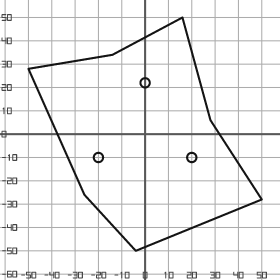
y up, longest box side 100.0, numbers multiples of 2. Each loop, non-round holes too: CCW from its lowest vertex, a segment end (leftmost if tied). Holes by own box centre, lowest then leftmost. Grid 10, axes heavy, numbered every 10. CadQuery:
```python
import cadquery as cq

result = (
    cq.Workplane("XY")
    .moveTo(-4.0, -50.0)
    .lineTo(50.0, -28.0)
    .lineTo(28.0, 6.0)
    .lineTo(16.0, 50.0)
    .lineTo(-14.0, 34.0)
    .lineTo(-50.0, 28.0)
    .lineTo(-26.0, -26.0)
    .close()
    .moveTo(-20.0, -10.0)
    .circle(2.0)
    .moveTo(20.0, -10.0)
    .circle(2.0)
    .moveTo(0.0, 22.0)
    .circle(2.0)
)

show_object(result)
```